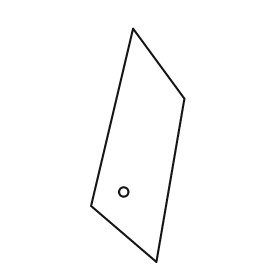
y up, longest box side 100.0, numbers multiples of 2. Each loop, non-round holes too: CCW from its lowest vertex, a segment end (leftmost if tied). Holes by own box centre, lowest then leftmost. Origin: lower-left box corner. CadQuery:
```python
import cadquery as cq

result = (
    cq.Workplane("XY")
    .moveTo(28.0, 0.0)
    .lineTo(40.0, 70.0)
    .lineTo(18.0, 100.0)
    .lineTo(0.0, 24.0)
    .close()
    .moveTo(14.0, 30.0)
    .circle(2.0)
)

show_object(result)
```